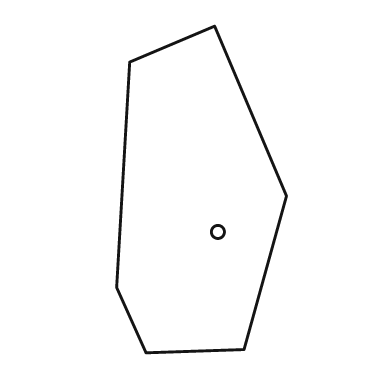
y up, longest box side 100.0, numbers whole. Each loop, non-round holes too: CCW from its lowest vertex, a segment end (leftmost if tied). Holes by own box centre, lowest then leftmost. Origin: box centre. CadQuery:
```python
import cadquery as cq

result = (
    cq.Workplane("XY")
    .moveTo(-17.0, -50.0)
    .lineTo(13.0, -49.0)
    .lineTo(26.0, -2.0)
    .lineTo(4.0, 50.0)
    .lineTo(-22.0, 39.0)
    .lineTo(-26.0, -30.0)
    .close()
    .moveTo(5.0, -13.0)
    .circle(2.0)
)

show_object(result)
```